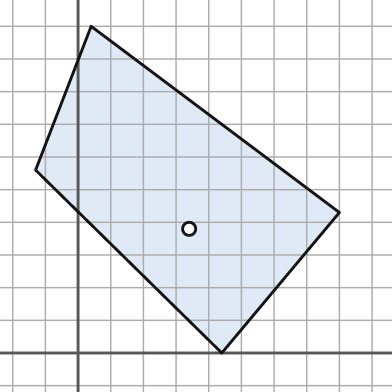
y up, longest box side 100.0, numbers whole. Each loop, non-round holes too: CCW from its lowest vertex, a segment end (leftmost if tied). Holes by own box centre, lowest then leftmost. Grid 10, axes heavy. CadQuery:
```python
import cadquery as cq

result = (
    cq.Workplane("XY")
    .moveTo(44.0, 0.0)
    .lineTo(80.0, 43.0)
    .lineTo(4.0, 100.0)
    .lineTo(-13.0, 56.0)
    .close()
    .moveTo(34.0, 38.0)
    .circle(2.0)
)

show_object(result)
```